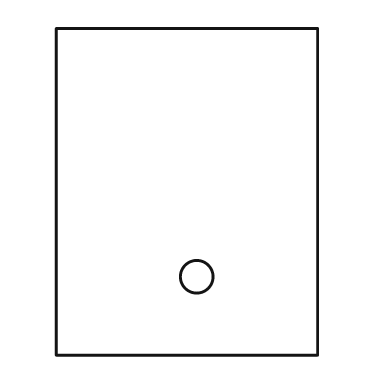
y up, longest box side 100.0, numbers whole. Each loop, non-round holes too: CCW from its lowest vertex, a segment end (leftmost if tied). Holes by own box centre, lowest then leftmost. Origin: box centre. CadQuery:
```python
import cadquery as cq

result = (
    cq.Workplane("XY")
    .moveTo(-40.0, -50.0)
    .lineTo(40.0, -50.0)
    .lineTo(40.0, 50.0)
    .lineTo(-40.0, 50.0)
    .close()
    .moveTo(3.0, -26.0)
    .circle(5.0)
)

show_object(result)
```